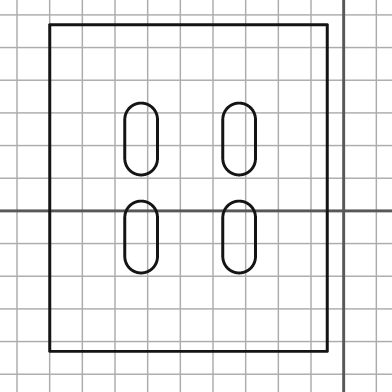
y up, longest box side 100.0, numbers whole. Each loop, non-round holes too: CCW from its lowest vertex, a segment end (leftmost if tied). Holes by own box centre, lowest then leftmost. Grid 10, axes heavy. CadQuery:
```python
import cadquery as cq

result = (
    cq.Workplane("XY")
    .moveTo(-90.0, -43.0)
    .lineTo(-5.0, -43.0)
    .lineTo(-5.0, 57.0)
    .lineTo(-90.0, 57.0)
    .close()
    .moveTo(-67.0, -14.0)
    .threePointArc((-62.0, -19.0), (-57.0, -14.0))
    .lineTo(-57.0, -2.0)
    .threePointArc((-62.0, 3.0), (-67.0, -2.0))
    .close()
    .moveTo(-37.0, -14.0)
    .threePointArc((-32.0, -19.0), (-27.0, -14.0))
    .lineTo(-27.0, -2.0)
    .threePointArc((-32.0, 3.0), (-37.0, -2.0))
    .close()
    .moveTo(-67.0, 16.0)
    .threePointArc((-62.0, 11.0), (-57.0, 16.0))
    .lineTo(-57.0, 28.0)
    .threePointArc((-62.0, 33.0), (-67.0, 28.0))
    .close()
    .moveTo(-37.0, 16.0)
    .threePointArc((-32.0, 11.0), (-27.0, 16.0))
    .lineTo(-27.0, 28.0)
    .threePointArc((-32.0, 33.0), (-37.0, 28.0))
    .close()
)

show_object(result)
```